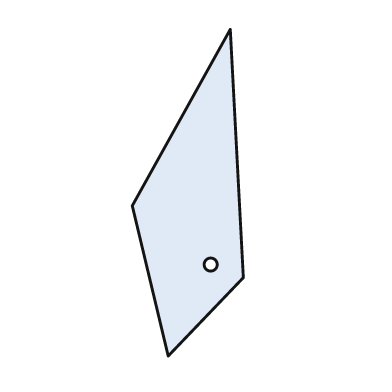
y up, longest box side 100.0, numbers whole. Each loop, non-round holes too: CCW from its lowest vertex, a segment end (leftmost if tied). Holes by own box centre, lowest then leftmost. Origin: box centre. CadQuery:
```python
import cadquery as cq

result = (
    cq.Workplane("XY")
    .moveTo(-6.0, -50.0)
    .lineTo(17.0, -26.0)
    .lineTo(13.0, 50.0)
    .lineTo(-17.0, -4.0)
    .close()
    .moveTo(7.0, -22.0)
    .circle(2.0)
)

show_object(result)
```